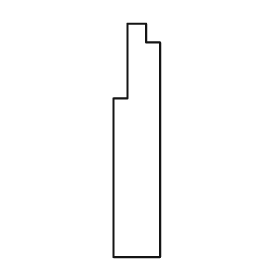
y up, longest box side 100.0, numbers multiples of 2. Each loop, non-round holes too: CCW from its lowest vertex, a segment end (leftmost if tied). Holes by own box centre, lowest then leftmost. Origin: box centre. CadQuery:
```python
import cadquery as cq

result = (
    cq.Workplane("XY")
    .moveTo(-10.0, -50.0)
    .lineTo(10.0, -50.0)
    .lineTo(10.0, 42.0)
    .lineTo(4.0, 42.0)
    .lineTo(4.0, 50.0)
    .lineTo(-4.0, 50.0)
    .lineTo(-4.0, 18.0)
    .lineTo(-10.0, 18.0)
    .close()
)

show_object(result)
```